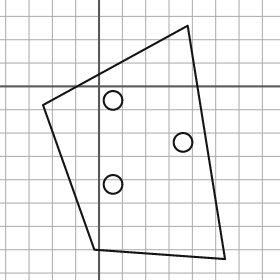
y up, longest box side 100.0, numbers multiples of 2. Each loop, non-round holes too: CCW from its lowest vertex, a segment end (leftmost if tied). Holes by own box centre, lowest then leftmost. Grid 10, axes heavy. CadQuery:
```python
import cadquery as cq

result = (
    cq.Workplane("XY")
    .moveTo(54.0, -74.0)
    .lineTo(38.0, 26.0)
    .lineTo(-24.0, -8.0)
    .lineTo(-2.0, -70.0)
    .close()
    .moveTo(6.0, -42.0)
    .circle(4.0)
    .moveTo(36.0, -24.0)
    .circle(4.0)
    .moveTo(6.0, -6.0)
    .circle(4.0)
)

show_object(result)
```